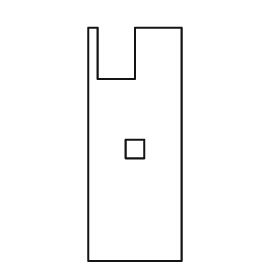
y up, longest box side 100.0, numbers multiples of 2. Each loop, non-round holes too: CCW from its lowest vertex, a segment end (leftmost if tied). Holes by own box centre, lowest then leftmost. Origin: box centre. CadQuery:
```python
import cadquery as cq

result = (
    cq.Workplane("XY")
    .moveTo(-20.0, -50.0)
    .lineTo(20.0, -50.0)
    .lineTo(20.0, 50.0)
    .lineTo(0.0, 50.0)
    .lineTo(0.0, 28.0)
    .lineTo(-16.0, 28.0)
    .lineTo(-16.0, 50.0)
    .lineTo(-20.0, 50.0)
    .close()
    .moveTo(-4.0, -6.0)
    .lineTo(4.0, -6.0)
    .lineTo(4.0, 2.0)
    .lineTo(-4.0, 2.0)
    .close()
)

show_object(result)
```